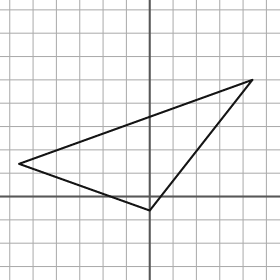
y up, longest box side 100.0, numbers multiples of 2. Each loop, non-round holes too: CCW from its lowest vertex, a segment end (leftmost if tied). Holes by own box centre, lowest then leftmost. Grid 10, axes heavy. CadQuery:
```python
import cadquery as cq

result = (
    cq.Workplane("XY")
    .moveTo(0.0, -6.0)
    .lineTo(44.0, 50.0)
    .lineTo(-56.0, 14.0)
    .close()
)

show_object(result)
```